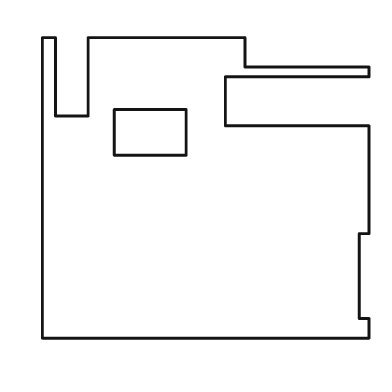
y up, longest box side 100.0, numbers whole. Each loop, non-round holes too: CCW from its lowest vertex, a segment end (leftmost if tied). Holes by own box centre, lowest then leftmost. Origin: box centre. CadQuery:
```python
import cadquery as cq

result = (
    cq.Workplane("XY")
    .moveTo(-50.0, -46.0)
    .lineTo(50.0, -46.0)
    .lineTo(50.0, -40.0)
    .lineTo(47.0, -40.0)
    .lineTo(47.0, -14.0)
    .lineTo(50.0, -14.0)
    .lineTo(50.0, 19.0)
    .lineTo(6.0, 19.0)
    .lineTo(6.0, 34.0)
    .lineTo(50.0, 34.0)
    .lineTo(50.0, 37.0)
    .lineTo(12.0, 37.0)
    .lineTo(12.0, 46.0)
    .lineTo(-36.0, 46.0)
    .lineTo(-36.0, 22.0)
    .lineTo(-46.0, 22.0)
    .lineTo(-46.0, 46.0)
    .lineTo(-50.0, 46.0)
    .close()
    .moveTo(-28.0, 10.0)
    .lineTo(-6.0, 10.0)
    .lineTo(-6.0, 24.0)
    .lineTo(-28.0, 24.0)
    .close()
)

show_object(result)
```